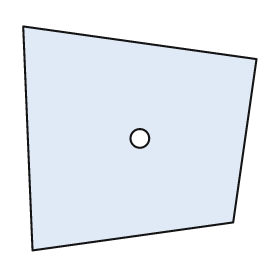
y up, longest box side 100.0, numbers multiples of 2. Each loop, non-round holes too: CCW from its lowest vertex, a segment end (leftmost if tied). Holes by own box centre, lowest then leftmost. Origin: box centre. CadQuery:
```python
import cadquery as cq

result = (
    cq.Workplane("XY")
    .moveTo(-46.0, -48.0)
    .lineTo(40.0, -36.0)
    .lineTo(50.0, 34.0)
    .lineTo(-50.0, 48.0)
    .close()
    .moveTo(0.0, 0.0)
    .circle(4.0)
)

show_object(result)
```